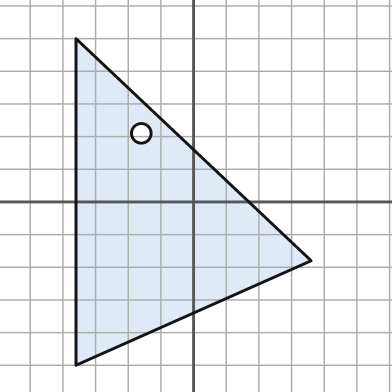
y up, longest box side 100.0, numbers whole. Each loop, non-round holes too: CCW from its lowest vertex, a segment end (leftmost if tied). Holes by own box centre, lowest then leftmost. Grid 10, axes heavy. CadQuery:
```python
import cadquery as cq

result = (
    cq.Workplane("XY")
    .moveTo(-36.0, -50.0)
    .lineTo(36.0, -18.0)
    .lineTo(-36.0, 50.0)
    .close()
    .moveTo(-16.0, 21.0)
    .circle(3.0)
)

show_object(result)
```